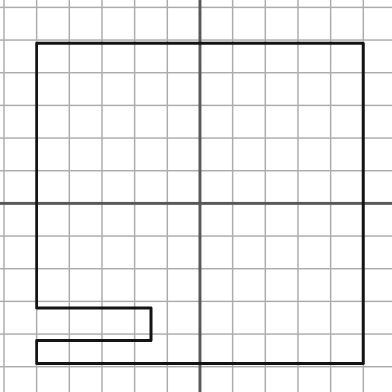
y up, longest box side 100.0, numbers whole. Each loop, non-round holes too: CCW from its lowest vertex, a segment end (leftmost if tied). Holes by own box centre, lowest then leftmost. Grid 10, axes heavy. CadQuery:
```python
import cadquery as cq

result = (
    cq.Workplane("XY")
    .moveTo(-50.0, -49.0)
    .lineTo(50.0, -49.0)
    .lineTo(50.0, 49.0)
    .lineTo(-50.0, 49.0)
    .lineTo(-50.0, -32.0)
    .lineTo(-15.0, -32.0)
    .lineTo(-15.0, -42.0)
    .lineTo(-50.0, -42.0)
    .close()
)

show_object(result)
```